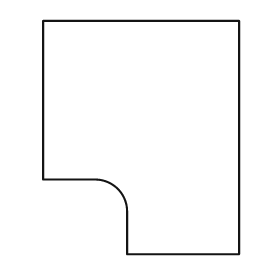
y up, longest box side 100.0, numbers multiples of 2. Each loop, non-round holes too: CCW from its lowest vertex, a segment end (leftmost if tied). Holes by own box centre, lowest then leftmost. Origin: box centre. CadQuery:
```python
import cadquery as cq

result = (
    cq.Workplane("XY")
    .moveTo(-6.0, -50.0)
    .lineTo(42.0, -50.0)
    .lineTo(42.0, 50.0)
    .lineTo(-42.0, 50.0)
    .lineTo(-42.0, -18.0)
    .lineTo(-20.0, -18.0)
    .threePointArc((-10.0, -22.0), (-6.0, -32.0))
    .close()
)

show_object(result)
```